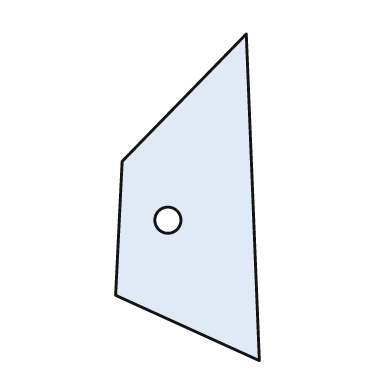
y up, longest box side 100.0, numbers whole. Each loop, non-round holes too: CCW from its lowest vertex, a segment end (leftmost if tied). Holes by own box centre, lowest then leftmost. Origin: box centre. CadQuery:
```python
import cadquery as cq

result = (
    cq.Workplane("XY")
    .moveTo(22.0, -50.0)
    .lineTo(18.0, 50.0)
    .lineTo(-20.0, 11.0)
    .lineTo(-22.0, -30.0)
    .close()
    .moveTo(-6.0, -7.0)
    .circle(4.0)
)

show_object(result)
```